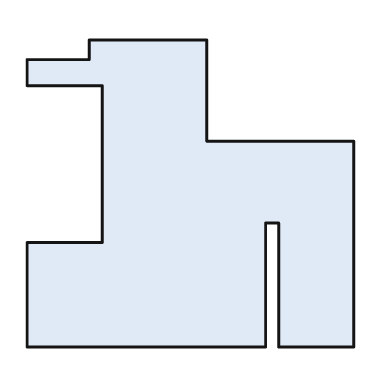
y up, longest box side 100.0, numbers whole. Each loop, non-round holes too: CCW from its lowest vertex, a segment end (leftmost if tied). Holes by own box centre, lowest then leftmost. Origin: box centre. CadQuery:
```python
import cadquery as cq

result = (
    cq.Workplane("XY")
    .moveTo(-50.0, -47.0)
    .lineTo(23.0, -47.0)
    .lineTo(23.0, -9.0)
    .lineTo(27.0, -9.0)
    .lineTo(27.0, -47.0)
    .lineTo(50.0, -47.0)
    .lineTo(50.0, 16.0)
    .lineTo(5.0, 16.0)
    .lineTo(5.0, 47.0)
    .lineTo(-31.0, 47.0)
    .lineTo(-31.0, 41.0)
    .lineTo(-50.0, 41.0)
    .lineTo(-50.0, 33.0)
    .lineTo(-27.0, 33.0)
    .lineTo(-27.0, -15.0)
    .lineTo(-50.0, -15.0)
    .close()
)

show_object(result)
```